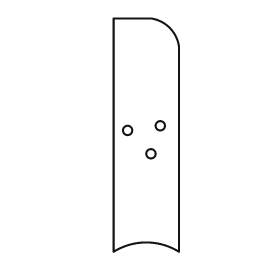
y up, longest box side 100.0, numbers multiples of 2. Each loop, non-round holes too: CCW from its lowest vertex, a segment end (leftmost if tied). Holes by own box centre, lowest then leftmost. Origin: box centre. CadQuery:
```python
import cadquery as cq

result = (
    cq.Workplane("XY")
    .moveTo(-14.0, -50.0)
    .threePointArc((0.0, -46.0), (14.0, -50.0))
    .lineTo(14.0, 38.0)
    .threePointArc((10.0, 46.0), (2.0, 50.0))
    .lineTo(-14.0, 50.0)
    .close()
    .moveTo(2.0, -8.0)
    .circle(2.0)
    .moveTo(-8.0, 2.0)
    .circle(2.0)
    .moveTo(6.0, 4.0)
    .circle(2.0)
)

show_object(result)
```